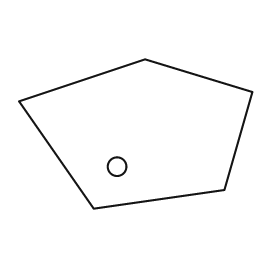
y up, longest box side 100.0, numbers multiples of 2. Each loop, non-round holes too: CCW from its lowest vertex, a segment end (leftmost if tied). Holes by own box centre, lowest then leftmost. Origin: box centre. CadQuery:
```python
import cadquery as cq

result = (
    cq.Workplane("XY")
    .moveTo(-18.0, -32.0)
    .lineTo(38.0, -24.0)
    .lineTo(50.0, 18.0)
    .lineTo(4.0, 32.0)
    .lineTo(-50.0, 14.0)
    .close()
    .moveTo(-8.0, -14.0)
    .circle(4.0)
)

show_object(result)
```